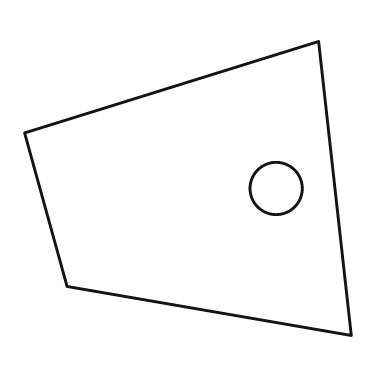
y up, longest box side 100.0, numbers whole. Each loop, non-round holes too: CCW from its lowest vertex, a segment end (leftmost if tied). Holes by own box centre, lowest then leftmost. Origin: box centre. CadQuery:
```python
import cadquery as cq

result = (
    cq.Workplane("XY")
    .moveTo(50.0, -45.0)
    .lineTo(40.0, 45.0)
    .lineTo(-50.0, 17.0)
    .lineTo(-37.0, -30.0)
    .close()
    .moveTo(27.0, 0.0)
    .circle(8.0)
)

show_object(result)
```